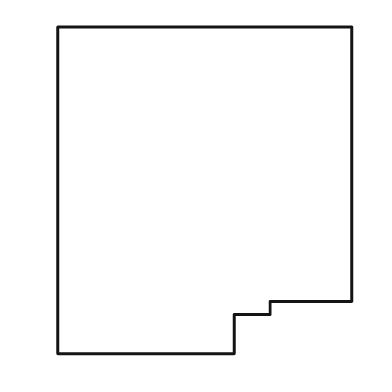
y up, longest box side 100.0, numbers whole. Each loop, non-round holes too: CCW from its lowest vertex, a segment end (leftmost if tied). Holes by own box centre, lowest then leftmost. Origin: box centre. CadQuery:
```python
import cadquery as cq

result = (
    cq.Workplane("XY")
    .moveTo(-45.0, -50.0)
    .lineTo(9.0, -50.0)
    .lineTo(9.0, -38.0)
    .lineTo(20.0, -38.0)
    .lineTo(20.0, -34.0)
    .lineTo(45.0, -34.0)
    .lineTo(45.0, 50.0)
    .lineTo(-45.0, 50.0)
    .close()
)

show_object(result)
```